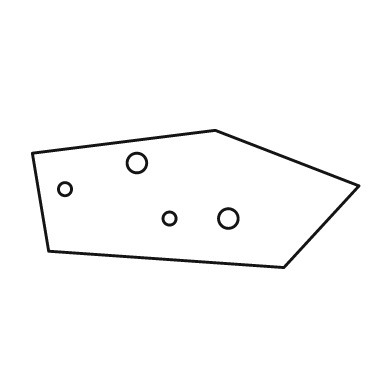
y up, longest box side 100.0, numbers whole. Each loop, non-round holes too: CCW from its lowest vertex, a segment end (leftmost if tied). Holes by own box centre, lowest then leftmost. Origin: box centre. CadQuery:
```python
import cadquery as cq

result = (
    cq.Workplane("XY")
    .moveTo(27.0, -21.0)
    .lineTo(50.0, 4.0)
    .lineTo(6.0, 21.0)
    .lineTo(-50.0, 14.0)
    .lineTo(-45.0, -16.0)
    .close()
    .moveTo(-8.0, -6.0)
    .circle(2.0)
    .moveTo(10.0, -6.0)
    .circle(3.0)
    .moveTo(-40.0, 3.0)
    .circle(2.0)
    .moveTo(-18.0, 11.0)
    .circle(3.0)
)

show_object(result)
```